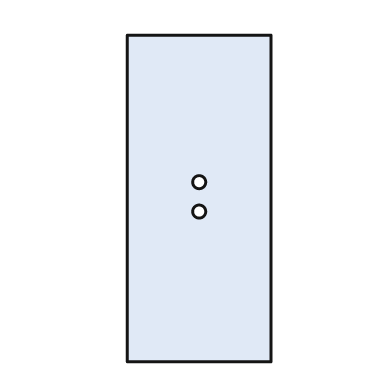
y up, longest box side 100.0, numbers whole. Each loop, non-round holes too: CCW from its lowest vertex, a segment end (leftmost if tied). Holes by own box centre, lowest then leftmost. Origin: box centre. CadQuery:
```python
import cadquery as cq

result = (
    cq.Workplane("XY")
    .moveTo(-22.0, -50.0)
    .lineTo(22.0, -50.0)
    .lineTo(22.0, 50.0)
    .lineTo(-22.0, 50.0)
    .close()
    .moveTo(0.0, -4.0)
    .circle(2.0)
    .moveTo(0.0, 5.0)
    .circle(2.0)
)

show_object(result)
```